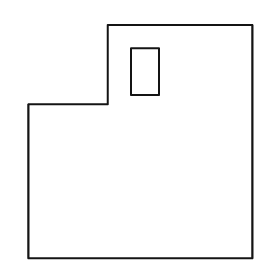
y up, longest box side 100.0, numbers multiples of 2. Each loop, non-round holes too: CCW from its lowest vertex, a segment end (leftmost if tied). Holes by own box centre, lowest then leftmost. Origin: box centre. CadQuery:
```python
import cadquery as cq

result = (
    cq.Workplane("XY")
    .moveTo(-48.0, -50.0)
    .lineTo(48.0, -50.0)
    .lineTo(48.0, 50.0)
    .lineTo(-14.0, 50.0)
    .lineTo(-14.0, 16.0)
    .lineTo(-48.0, 16.0)
    .close()
    .moveTo(-4.0, 20.0)
    .lineTo(8.0, 20.0)
    .lineTo(8.0, 40.0)
    .lineTo(-4.0, 40.0)
    .close()
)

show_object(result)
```